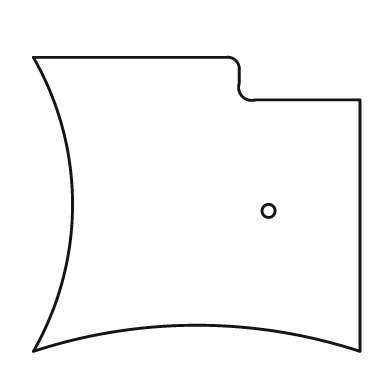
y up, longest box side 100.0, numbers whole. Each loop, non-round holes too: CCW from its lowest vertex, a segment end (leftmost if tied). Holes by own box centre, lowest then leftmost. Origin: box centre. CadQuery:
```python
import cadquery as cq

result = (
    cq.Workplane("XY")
    .moveTo(-50.0, -45.0)
    .threePointArc((0.0, -37.0), (50.0, -45.0))
    .lineTo(50.0, 32.0)
    .lineTo(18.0, 32.0)
    .threePointArc((14.0, 33.0), (13.0, 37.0))
    .lineTo(13.0, 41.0)
    .threePointArc((12.0, 44.0), (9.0, 45.0))
    .lineTo(-50.0, 45.0)
    .threePointArc((-38.0, 0.0), (-50.0, -45.0))
    .close()
    .moveTo(22.0, -2.0)
    .circle(2.0)
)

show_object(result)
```